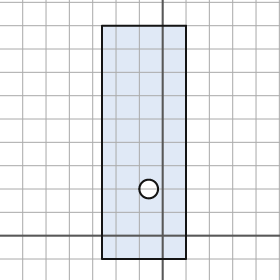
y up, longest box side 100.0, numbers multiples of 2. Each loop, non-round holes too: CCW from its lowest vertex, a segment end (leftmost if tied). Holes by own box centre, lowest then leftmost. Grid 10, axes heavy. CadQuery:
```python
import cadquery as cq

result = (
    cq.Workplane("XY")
    .moveTo(-26.0, -10.0)
    .lineTo(10.0, -10.0)
    .lineTo(10.0, 90.0)
    .lineTo(-26.0, 90.0)
    .close()
    .moveTo(-6.0, 20.0)
    .circle(4.0)
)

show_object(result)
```